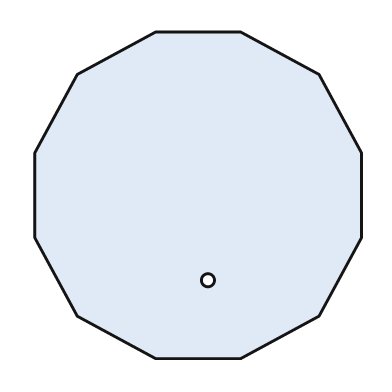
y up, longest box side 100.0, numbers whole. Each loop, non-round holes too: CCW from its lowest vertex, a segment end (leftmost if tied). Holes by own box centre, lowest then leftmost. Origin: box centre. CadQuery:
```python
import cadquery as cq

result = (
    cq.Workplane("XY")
    .moveTo(-13.0, -50.0)
    .lineTo(13.0, -50.0)
    .lineTo(37.0, -37.0)
    .lineTo(50.0, -13.0)
    .lineTo(50.0, 13.0)
    .lineTo(37.0, 37.0)
    .lineTo(13.0, 50.0)
    .lineTo(-13.0, 50.0)
    .lineTo(-37.0, 37.0)
    .lineTo(-50.0, 13.0)
    .lineTo(-50.0, -13.0)
    .lineTo(-37.0, -37.0)
    .close()
    .moveTo(3.0, -26.0)
    .circle(2.0)
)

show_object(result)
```